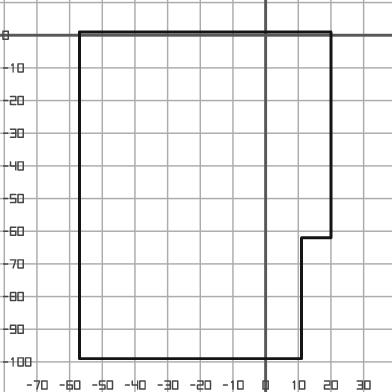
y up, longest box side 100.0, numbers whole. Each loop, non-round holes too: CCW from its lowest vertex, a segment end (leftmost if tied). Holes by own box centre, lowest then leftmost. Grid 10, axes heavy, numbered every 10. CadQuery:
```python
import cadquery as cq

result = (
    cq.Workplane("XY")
    .moveTo(-57.0, -99.0)
    .lineTo(11.0, -99.0)
    .lineTo(11.0, -62.0)
    .lineTo(20.0, -62.0)
    .lineTo(20.0, 1.0)
    .lineTo(-57.0, 1.0)
    .close()
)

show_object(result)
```